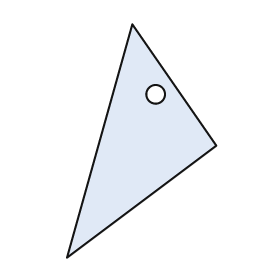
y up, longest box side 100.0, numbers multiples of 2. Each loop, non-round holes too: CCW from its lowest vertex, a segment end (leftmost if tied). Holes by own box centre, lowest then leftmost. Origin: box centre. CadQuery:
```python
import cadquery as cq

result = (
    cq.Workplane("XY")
    .moveTo(-32.0, -50.0)
    .lineTo(32.0, -2.0)
    .lineTo(-4.0, 50.0)
    .close()
    .moveTo(6.0, 20.0)
    .circle(4.0)
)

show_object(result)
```